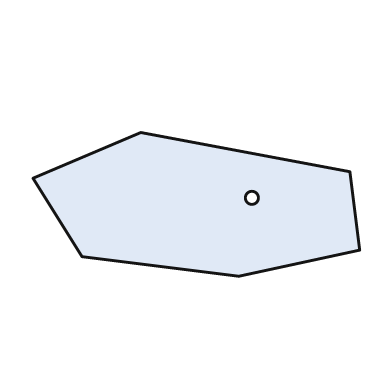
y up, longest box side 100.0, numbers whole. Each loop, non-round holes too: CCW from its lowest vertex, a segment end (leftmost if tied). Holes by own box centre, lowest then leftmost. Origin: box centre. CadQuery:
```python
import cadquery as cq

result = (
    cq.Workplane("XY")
    .moveTo(13.0, -22.0)
    .lineTo(50.0, -14.0)
    .lineTo(47.0, 10.0)
    .lineTo(-17.0, 22.0)
    .lineTo(-50.0, 8.0)
    .lineTo(-35.0, -16.0)
    .close()
    .moveTo(17.0, 2.0)
    .circle(2.0)
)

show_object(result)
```